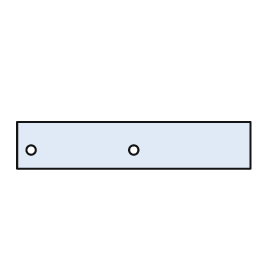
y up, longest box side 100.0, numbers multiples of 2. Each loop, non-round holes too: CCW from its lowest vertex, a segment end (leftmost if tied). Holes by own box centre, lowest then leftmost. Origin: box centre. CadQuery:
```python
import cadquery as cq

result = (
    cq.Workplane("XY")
    .moveTo(-50.0, -10.0)
    .lineTo(50.0, -10.0)
    .lineTo(50.0, 10.0)
    .lineTo(-50.0, 10.0)
    .close()
    .moveTo(-44.0, -2.0)
    .circle(2.0)
    .moveTo(0.0, -2.0)
    .circle(2.0)
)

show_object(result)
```